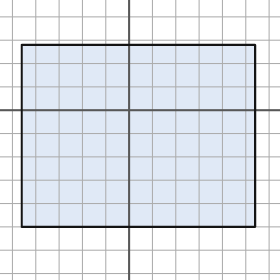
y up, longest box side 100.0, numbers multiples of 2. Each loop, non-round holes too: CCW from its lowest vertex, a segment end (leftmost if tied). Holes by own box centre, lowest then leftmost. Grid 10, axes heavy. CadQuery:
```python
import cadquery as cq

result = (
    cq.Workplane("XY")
    .moveTo(-46.0, -50.0)
    .lineTo(54.0, -50.0)
    .lineTo(54.0, 28.0)
    .lineTo(-46.0, 28.0)
    .close()
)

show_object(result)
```